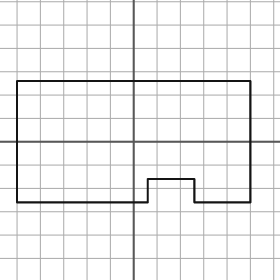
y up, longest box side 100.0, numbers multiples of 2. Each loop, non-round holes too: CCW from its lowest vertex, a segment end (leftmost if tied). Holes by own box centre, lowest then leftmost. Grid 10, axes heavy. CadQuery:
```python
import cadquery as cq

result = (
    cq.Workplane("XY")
    .moveTo(-50.0, -26.0)
    .lineTo(6.0, -26.0)
    .lineTo(6.0, -16.0)
    .lineTo(26.0, -16.0)
    .lineTo(26.0, -26.0)
    .lineTo(50.0, -26.0)
    .lineTo(50.0, 26.0)
    .lineTo(-50.0, 26.0)
    .close()
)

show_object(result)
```